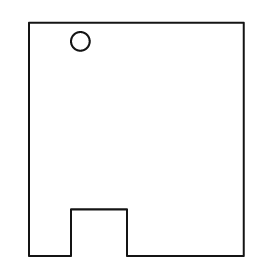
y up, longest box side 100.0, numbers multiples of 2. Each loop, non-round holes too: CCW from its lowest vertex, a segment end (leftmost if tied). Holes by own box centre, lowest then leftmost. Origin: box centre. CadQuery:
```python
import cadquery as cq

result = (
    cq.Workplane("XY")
    .moveTo(-46.0, -50.0)
    .lineTo(-28.0, -50.0)
    .lineTo(-28.0, -30.0)
    .lineTo(-4.0, -30.0)
    .lineTo(-4.0, -50.0)
    .lineTo(46.0, -50.0)
    .lineTo(46.0, 50.0)
    .lineTo(-46.0, 50.0)
    .close()
    .moveTo(-24.0, 42.0)
    .circle(4.0)
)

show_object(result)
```